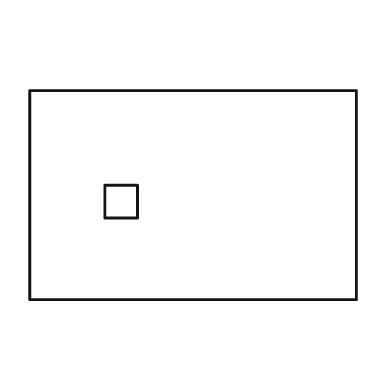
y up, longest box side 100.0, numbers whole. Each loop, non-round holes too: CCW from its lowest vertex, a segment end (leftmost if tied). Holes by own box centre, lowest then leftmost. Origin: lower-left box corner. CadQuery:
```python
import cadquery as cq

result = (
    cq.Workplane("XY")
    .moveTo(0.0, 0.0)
    .lineTo(100.0, 0.0)
    .lineTo(100.0, 64.0)
    .lineTo(0.0, 64.0)
    .close()
    .moveTo(23.0, 25.0)
    .lineTo(33.0, 25.0)
    .lineTo(33.0, 35.0)
    .lineTo(23.0, 35.0)
    .close()
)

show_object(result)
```